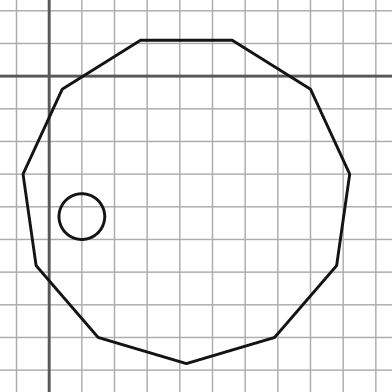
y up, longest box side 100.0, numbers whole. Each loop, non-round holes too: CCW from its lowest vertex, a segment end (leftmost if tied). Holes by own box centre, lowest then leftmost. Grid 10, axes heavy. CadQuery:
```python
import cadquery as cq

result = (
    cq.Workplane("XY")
    .moveTo(42.0, -88.0)
    .lineTo(69.0, -80.0)
    .lineTo(88.0, -58.0)
    .lineTo(92.0, -30.0)
    .lineTo(80.0, -4.0)
    .lineTo(56.0, 11.0)
    .lineTo(28.0, 11.0)
    .lineTo(4.0, -4.0)
    .lineTo(-8.0, -30.0)
    .lineTo(-4.0, -58.0)
    .lineTo(15.0, -80.0)
    .close()
    .moveTo(10.0, -43.0)
    .circle(7.0)
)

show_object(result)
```